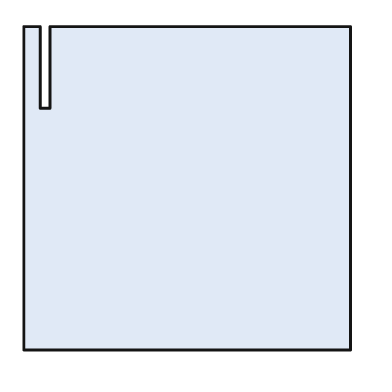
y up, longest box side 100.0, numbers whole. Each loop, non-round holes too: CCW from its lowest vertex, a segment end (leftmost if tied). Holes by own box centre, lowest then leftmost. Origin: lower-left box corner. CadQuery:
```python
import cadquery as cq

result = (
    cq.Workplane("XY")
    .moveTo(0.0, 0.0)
    .lineTo(100.0, 0.0)
    .lineTo(100.0, 99.0)
    .lineTo(8.0, 99.0)
    .lineTo(8.0, 74.0)
    .lineTo(5.0, 74.0)
    .lineTo(5.0, 99.0)
    .lineTo(0.0, 99.0)
    .close()
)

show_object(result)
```